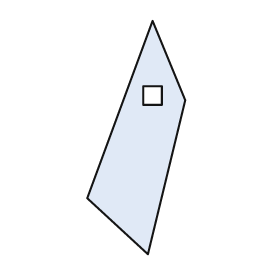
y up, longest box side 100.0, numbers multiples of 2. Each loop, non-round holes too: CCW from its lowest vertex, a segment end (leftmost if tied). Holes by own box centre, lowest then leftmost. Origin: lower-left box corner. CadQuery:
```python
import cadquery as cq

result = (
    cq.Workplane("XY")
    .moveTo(26.0, 0.0)
    .lineTo(42.0, 66.0)
    .lineTo(28.0, 100.0)
    .lineTo(0.0, 24.0)
    .close()
    .moveTo(24.0, 64.0)
    .lineTo(32.0, 64.0)
    .lineTo(32.0, 72.0)
    .lineTo(24.0, 72.0)
    .close()
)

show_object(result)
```